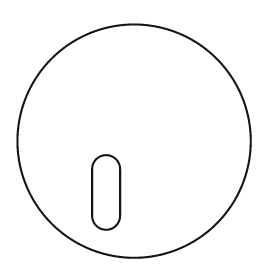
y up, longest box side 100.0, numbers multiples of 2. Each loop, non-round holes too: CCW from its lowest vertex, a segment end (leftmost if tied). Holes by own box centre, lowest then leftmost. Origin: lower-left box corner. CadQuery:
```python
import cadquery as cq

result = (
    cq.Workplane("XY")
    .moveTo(50.0, 50.0)
    .circle(50.0)
    .moveTo(32.0, 18.0)
    .threePointArc((38.0, 12.0), (44.0, 18.0))
    .lineTo(44.0, 38.0)
    .threePointArc((38.0, 44.0), (32.0, 38.0))
    .close()
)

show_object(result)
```